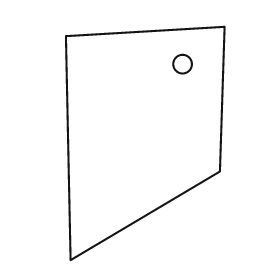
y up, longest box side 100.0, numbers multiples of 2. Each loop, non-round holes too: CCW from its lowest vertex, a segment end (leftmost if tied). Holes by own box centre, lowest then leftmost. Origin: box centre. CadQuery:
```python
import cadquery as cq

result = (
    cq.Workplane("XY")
    .moveTo(-32.0, -50.0)
    .lineTo(32.0, -12.0)
    .lineTo(34.0, 50.0)
    .lineTo(-34.0, 46.0)
    .close()
    .moveTo(16.0, 34.0)
    .circle(4.0)
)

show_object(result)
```